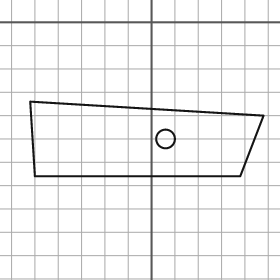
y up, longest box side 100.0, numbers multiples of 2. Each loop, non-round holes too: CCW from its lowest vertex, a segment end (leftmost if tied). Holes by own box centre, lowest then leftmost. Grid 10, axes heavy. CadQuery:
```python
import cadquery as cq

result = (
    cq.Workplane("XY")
    .moveTo(-50.0, -66.0)
    .lineTo(38.0, -66.0)
    .lineTo(48.0, -40.0)
    .lineTo(-52.0, -34.0)
    .close()
    .moveTo(6.0, -50.0)
    .circle(4.0)
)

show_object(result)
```